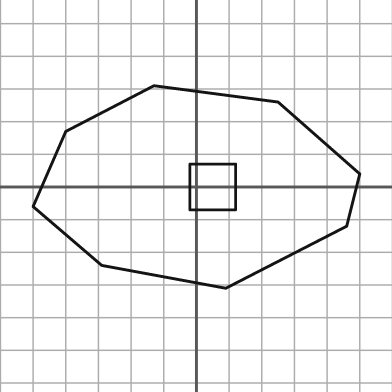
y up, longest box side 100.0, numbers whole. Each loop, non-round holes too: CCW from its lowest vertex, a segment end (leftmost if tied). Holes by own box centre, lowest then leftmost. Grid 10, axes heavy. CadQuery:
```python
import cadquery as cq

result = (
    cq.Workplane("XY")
    .moveTo(9.0, -31.0)
    .lineTo(46.0, -12.0)
    .lineTo(50.0, 4.0)
    .lineTo(25.0, 26.0)
    .lineTo(-13.0, 31.0)
    .lineTo(-40.0, 17.0)
    .lineTo(-50.0, -6.0)
    .lineTo(-29.0, -24.0)
    .close()
    .moveTo(-2.0, -7.0)
    .lineTo(12.0, -7.0)
    .lineTo(12.0, 7.0)
    .lineTo(-2.0, 7.0)
    .close()
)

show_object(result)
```